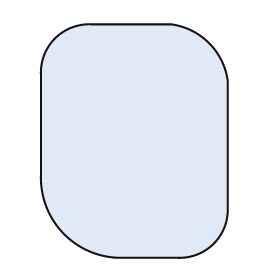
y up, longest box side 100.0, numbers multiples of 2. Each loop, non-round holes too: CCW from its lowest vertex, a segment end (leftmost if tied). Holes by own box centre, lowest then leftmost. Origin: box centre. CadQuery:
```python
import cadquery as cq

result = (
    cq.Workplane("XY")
    .moveTo(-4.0, -50.0)
    .lineTo(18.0, -50.0)
    .threePointArc((34.0, -44.0), (40.0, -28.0))
    .lineTo(40.0, 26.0)
    .threePointArc((32.0, 42.0), (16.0, 50.0))
    .lineTo(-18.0, 50.0)
    .threePointArc((-34.0, 44.0), (-40.0, 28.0))
    .lineTo(-40.0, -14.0)
    .threePointArc((-30.0, -40.0), (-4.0, -50.0))
    .close()
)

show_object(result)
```